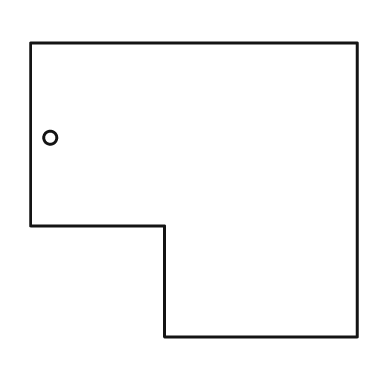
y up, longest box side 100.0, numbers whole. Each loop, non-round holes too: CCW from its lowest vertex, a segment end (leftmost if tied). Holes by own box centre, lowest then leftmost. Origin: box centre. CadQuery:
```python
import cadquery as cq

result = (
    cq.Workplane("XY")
    .moveTo(-9.0, -45.0)
    .lineTo(50.0, -45.0)
    .lineTo(50.0, 45.0)
    .lineTo(-50.0, 45.0)
    .lineTo(-50.0, -11.0)
    .lineTo(-9.0, -11.0)
    .close()
    .moveTo(-44.0, 16.0)
    .circle(2.0)
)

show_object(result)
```